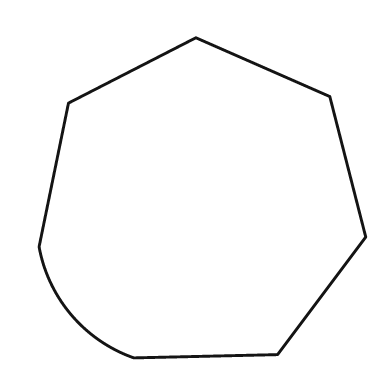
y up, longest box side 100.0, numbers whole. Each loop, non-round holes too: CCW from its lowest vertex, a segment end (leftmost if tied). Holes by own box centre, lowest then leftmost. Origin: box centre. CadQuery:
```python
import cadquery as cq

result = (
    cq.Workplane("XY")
    .moveTo(-21.0, -49.0)
    .lineTo(23.0, -48.0)
    .lineTo(50.0, -12.0)
    .lineTo(39.0, 31.0)
    .lineTo(-2.0, 49.0)
    .lineTo(-41.0, 29.0)
    .lineTo(-50.0, -15.0)
    .threePointArc((-40.0, -36.0), (-21.0, -49.0))
    .close()
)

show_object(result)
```